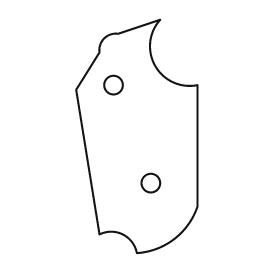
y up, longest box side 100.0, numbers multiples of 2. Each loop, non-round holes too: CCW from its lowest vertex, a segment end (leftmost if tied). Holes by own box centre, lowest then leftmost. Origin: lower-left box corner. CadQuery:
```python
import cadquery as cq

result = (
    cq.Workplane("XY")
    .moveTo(26.0, 0.0)
    .threePointArc((42.0, 6.0), (52.0, 20.0))
    .lineTo(52.0, 72.0)
    .threePointArc((34.0, 80.0), (36.0, 100.0))
    .lineTo(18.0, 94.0)
    .threePointArc((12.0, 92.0), (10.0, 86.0))
    .lineTo(0.0, 70.0)
    .lineTo(10.0, 8.0)
    .threePointArc((20.0, 8.0), (26.0, 0.0))
    .close()
    .moveTo(32.0, 30.0)
    .circle(4.0)
    .moveTo(16.0, 72.0)
    .circle(4.0)
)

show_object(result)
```